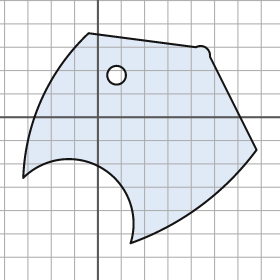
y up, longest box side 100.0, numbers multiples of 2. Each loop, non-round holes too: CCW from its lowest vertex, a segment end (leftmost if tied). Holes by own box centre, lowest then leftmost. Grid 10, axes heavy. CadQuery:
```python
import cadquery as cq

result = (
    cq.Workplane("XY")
    .moveTo(14.0, -54.0)
    .threePointArc((44.0, -38.0), (68.0, -14.0))
    .lineTo(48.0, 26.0)
    .threePointArc((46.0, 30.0), (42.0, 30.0))
    .lineTo(-4.0, 36.0)
    .threePointArc((-24.0, 8.0), (-32.0, -26.0))
    .threePointArc((2.0, -22.0), (14.0, -54.0))
    .close()
    .moveTo(8.0, 18.0)
    .circle(4.0)
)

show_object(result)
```